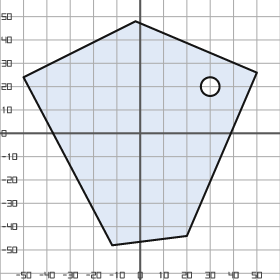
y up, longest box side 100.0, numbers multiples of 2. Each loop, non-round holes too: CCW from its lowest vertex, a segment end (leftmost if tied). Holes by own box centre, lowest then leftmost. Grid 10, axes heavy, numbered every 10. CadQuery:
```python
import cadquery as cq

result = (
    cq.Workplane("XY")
    .moveTo(-12.0, -48.0)
    .lineTo(20.0, -44.0)
    .lineTo(50.0, 26.0)
    .lineTo(-2.0, 48.0)
    .lineTo(-50.0, 24.0)
    .close()
    .moveTo(30.0, 20.0)
    .circle(4.0)
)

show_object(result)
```